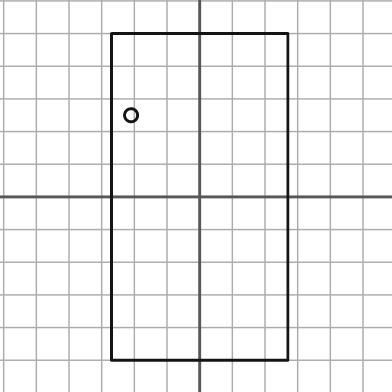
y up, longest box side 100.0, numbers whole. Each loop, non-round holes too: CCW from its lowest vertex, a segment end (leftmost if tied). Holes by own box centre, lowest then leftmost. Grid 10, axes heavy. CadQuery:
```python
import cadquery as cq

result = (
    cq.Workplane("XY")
    .moveTo(-27.0, -50.0)
    .lineTo(27.0, -50.0)
    .lineTo(27.0, 50.0)
    .lineTo(-27.0, 50.0)
    .close()
    .moveTo(-21.0, 25.0)
    .circle(2.0)
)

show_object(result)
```